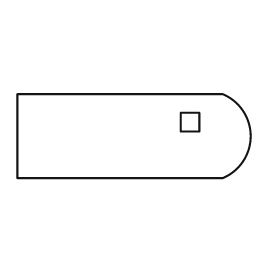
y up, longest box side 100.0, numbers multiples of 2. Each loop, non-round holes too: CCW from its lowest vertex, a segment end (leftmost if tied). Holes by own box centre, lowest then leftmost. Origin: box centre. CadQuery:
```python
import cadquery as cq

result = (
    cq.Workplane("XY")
    .moveTo(-50.0, -18.0)
    .lineTo(38.0, -18.0)
    .threePointArc((50.0, 0.0), (38.0, 18.0))
    .lineTo(-50.0, 18.0)
    .close()
    .moveTo(20.0, 2.0)
    .lineTo(28.0, 2.0)
    .lineTo(28.0, 10.0)
    .lineTo(20.0, 10.0)
    .close()
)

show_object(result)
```